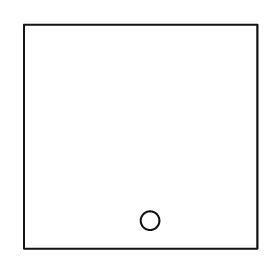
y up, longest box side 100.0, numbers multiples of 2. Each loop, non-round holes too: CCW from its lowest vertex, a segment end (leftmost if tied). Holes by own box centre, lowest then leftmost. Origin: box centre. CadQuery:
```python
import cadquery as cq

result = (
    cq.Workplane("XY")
    .moveTo(-50.0, -48.0)
    .lineTo(50.0, -48.0)
    .lineTo(50.0, 48.0)
    .lineTo(-50.0, 48.0)
    .close()
    .moveTo(4.0, -36.0)
    .circle(4.0)
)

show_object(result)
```